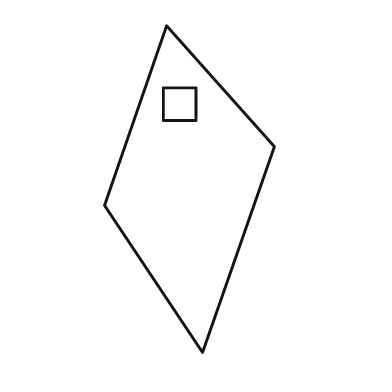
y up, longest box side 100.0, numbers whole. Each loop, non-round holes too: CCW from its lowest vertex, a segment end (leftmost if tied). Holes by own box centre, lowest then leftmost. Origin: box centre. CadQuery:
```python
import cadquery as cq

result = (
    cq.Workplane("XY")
    .moveTo(4.0, -50.0)
    .lineTo(26.0, 13.0)
    .lineTo(-7.0, 50.0)
    .lineTo(-26.0, -5.0)
    .close()
    .moveTo(-8.0, 21.0)
    .lineTo(2.0, 21.0)
    .lineTo(2.0, 31.0)
    .lineTo(-8.0, 31.0)
    .close()
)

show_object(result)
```